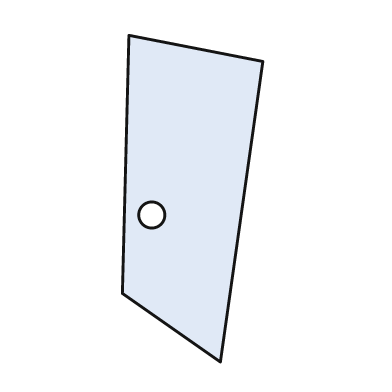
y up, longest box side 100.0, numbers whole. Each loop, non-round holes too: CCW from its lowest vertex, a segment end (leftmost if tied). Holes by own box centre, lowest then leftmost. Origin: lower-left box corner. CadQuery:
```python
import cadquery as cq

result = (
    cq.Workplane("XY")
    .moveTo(30.0, 0.0)
    .lineTo(43.0, 92.0)
    .lineTo(2.0, 100.0)
    .lineTo(0.0, 21.0)
    .close()
    .moveTo(9.0, 45.0)
    .circle(4.0)
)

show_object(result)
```